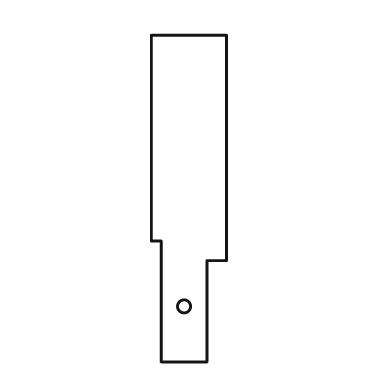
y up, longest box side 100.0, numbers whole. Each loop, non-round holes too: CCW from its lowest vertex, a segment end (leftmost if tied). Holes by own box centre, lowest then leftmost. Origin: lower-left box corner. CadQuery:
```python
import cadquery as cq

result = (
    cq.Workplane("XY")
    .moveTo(3.0, 0.0)
    .lineTo(17.0, 0.0)
    .lineTo(17.0, 31.0)
    .lineTo(23.0, 31.0)
    .lineTo(23.0, 100.0)
    .lineTo(0.0, 100.0)
    .lineTo(0.0, 37.0)
    .lineTo(3.0, 37.0)
    .close()
    .moveTo(10.0, 17.0)
    .circle(2.0)
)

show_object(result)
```